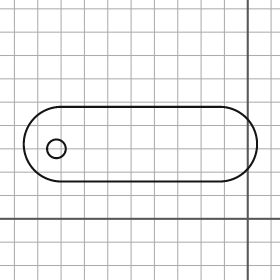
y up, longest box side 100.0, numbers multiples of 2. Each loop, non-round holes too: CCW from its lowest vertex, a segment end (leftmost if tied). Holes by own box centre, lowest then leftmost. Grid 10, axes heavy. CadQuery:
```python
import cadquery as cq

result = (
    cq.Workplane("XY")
    .moveTo(-80.0, 16.0)
    .lineTo(-12.0, 16.0)
    .threePointArc((4.0, 32.0), (-12.0, 48.0))
    .lineTo(-80.0, 48.0)
    .threePointArc((-96.0, 32.0), (-80.0, 16.0))
    .close()
    .moveTo(-82.0, 30.0)
    .circle(4.0)
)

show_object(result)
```